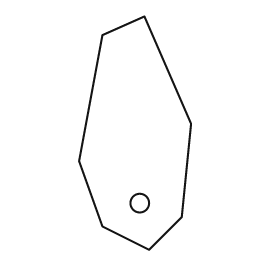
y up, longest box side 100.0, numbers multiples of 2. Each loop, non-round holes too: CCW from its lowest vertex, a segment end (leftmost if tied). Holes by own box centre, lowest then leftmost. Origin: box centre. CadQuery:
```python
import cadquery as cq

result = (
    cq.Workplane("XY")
    .moveTo(6.0, -50.0)
    .lineTo(20.0, -36.0)
    .lineTo(24.0, 4.0)
    .lineTo(4.0, 50.0)
    .lineTo(-14.0, 42.0)
    .lineTo(-24.0, -12.0)
    .lineTo(-14.0, -40.0)
    .close()
    .moveTo(2.0, -30.0)
    .circle(4.0)
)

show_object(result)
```